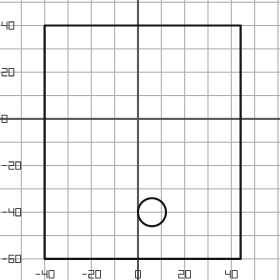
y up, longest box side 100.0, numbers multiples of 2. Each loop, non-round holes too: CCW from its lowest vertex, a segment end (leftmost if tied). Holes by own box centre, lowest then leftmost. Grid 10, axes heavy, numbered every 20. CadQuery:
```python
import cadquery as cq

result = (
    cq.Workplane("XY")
    .moveTo(-40.0, -60.0)
    .lineTo(44.0, -60.0)
    .lineTo(44.0, 40.0)
    .lineTo(-40.0, 40.0)
    .close()
    .moveTo(6.0, -40.0)
    .circle(6.0)
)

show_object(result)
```